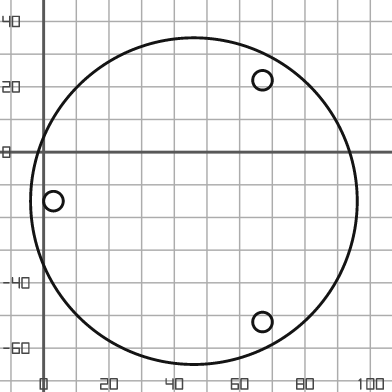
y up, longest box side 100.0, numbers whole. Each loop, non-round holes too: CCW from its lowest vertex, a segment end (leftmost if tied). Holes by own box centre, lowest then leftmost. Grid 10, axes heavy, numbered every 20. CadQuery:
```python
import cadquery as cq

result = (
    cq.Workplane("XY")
    .moveTo(46.0, -15.0)
    .circle(50.0)
    .moveTo(67.0, -52.0)
    .circle(3.0)
    .moveTo(3.0, -15.0)
    .circle(3.0)
    .moveTo(67.0, 22.0)
    .circle(3.0)
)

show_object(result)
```